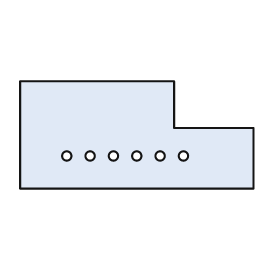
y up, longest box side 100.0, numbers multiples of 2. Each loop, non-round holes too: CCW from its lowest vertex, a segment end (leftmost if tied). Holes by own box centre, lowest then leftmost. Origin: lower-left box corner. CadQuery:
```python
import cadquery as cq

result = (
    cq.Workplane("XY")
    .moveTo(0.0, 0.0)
    .lineTo(100.0, 0.0)
    .lineTo(100.0, 26.0)
    .lineTo(66.0, 26.0)
    .lineTo(66.0, 46.0)
    .lineTo(0.0, 46.0)
    .close()
    .moveTo(20.0, 14.0)
    .circle(2.0)
    .moveTo(30.0, 14.0)
    .circle(2.0)
    .moveTo(40.0, 14.0)
    .circle(2.0)
    .moveTo(50.0, 14.0)
    .circle(2.0)
    .moveTo(60.0, 14.0)
    .circle(2.0)
    .moveTo(70.0, 14.0)
    .circle(2.0)
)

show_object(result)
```